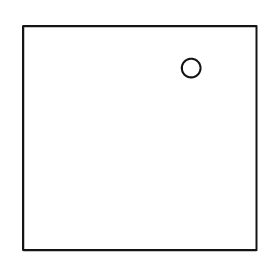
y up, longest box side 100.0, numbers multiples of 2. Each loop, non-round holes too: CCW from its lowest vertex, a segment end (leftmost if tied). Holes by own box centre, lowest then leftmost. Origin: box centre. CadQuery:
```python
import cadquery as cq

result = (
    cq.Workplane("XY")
    .moveTo(-50.0, -48.0)
    .lineTo(50.0, -48.0)
    .lineTo(50.0, 48.0)
    .lineTo(-50.0, 48.0)
    .close()
    .moveTo(22.0, 30.0)
    .circle(4.0)
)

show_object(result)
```